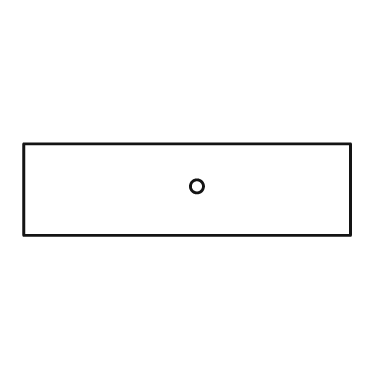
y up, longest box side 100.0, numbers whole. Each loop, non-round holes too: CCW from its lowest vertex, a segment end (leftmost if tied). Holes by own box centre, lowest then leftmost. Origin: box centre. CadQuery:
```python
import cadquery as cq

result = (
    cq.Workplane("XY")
    .moveTo(-50.0, -14.0)
    .lineTo(50.0, -14.0)
    .lineTo(50.0, 14.0)
    .lineTo(-50.0, 14.0)
    .close()
    .moveTo(3.0, 1.0)
    .circle(2.0)
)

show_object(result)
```